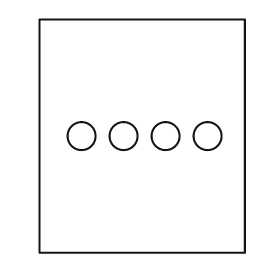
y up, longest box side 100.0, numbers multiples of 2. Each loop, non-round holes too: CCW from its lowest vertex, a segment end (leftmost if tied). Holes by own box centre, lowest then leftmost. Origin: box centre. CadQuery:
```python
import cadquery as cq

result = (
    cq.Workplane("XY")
    .moveTo(-44.0, -50.0)
    .lineTo(44.0, -50.0)
    .lineTo(44.0, 50.0)
    .lineTo(-44.0, 50.0)
    .close()
    .moveTo(-26.0, 0.0)
    .circle(6.0)
    .moveTo(-8.0, 0.0)
    .circle(6.0)
    .moveTo(10.0, 0.0)
    .circle(6.0)
    .moveTo(28.0, 0.0)
    .circle(6.0)
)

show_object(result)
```